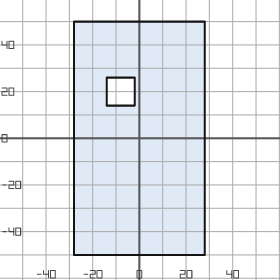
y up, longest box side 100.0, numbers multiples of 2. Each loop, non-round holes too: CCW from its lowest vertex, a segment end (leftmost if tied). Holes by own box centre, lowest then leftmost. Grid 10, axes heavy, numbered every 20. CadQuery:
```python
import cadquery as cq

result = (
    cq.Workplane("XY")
    .moveTo(-28.0, -50.0)
    .lineTo(28.0, -50.0)
    .lineTo(28.0, 50.0)
    .lineTo(-28.0, 50.0)
    .close()
    .moveTo(-14.0, 14.0)
    .lineTo(-2.0, 14.0)
    .lineTo(-2.0, 26.0)
    .lineTo(-14.0, 26.0)
    .close()
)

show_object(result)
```